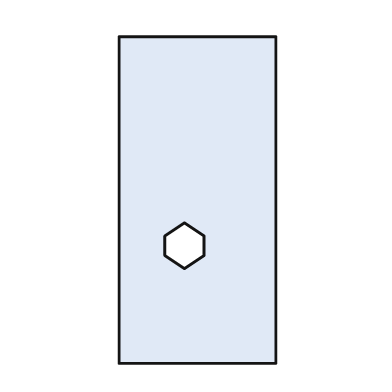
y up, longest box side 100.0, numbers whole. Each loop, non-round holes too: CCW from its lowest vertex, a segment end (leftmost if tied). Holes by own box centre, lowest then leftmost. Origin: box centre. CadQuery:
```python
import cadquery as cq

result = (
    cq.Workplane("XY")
    .moveTo(-24.0, -50.0)
    .lineTo(24.0, -50.0)
    .lineTo(24.0, 50.0)
    .lineTo(-24.0, 50.0)
    .close()
    .moveTo(-4.0, -21.0)
    .lineTo(2.0, -17.0)
    .lineTo(2.0, -11.0)
    .lineTo(-4.0, -7.0)
    .lineTo(-10.0, -11.0)
    .lineTo(-10.0, -17.0)
    .close()
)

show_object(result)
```